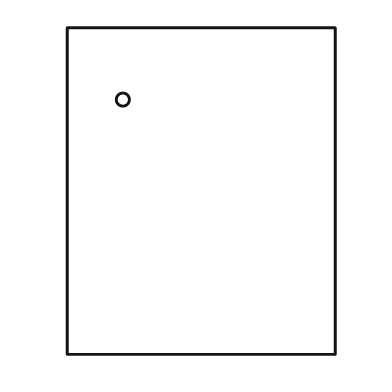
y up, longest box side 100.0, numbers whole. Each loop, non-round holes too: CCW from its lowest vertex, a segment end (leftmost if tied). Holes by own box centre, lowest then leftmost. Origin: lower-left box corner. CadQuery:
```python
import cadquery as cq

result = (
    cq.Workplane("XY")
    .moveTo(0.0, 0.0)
    .lineTo(82.0, 0.0)
    .lineTo(82.0, 100.0)
    .lineTo(0.0, 100.0)
    .close()
    .moveTo(17.0, 78.0)
    .circle(2.0)
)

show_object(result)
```